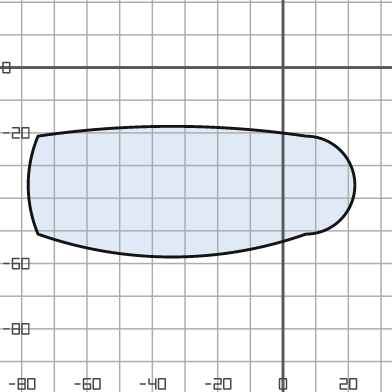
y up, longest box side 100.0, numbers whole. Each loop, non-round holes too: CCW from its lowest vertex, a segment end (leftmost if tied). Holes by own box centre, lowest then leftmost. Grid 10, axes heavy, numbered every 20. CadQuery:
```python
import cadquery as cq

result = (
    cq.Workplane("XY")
    .moveTo(-75.0, -51.0)
    .threePointArc((-34.0, -58.0), (7.0, -51.0))
    .threePointArc((22.0, -36.0), (7.0, -21.0))
    .threePointArc((-34.0, -18.0), (-75.0, -21.0))
    .threePointArc((-78.0, -36.0), (-75.0, -51.0))
    .close()
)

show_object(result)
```